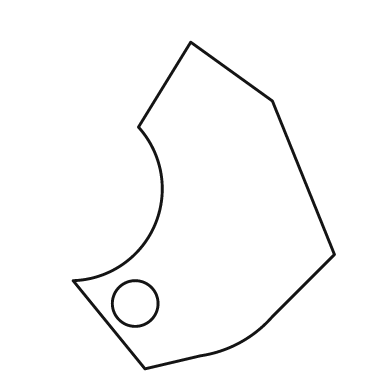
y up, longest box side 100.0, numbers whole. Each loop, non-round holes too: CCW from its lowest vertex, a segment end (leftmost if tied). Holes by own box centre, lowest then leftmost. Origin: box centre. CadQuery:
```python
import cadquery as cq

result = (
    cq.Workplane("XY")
    .moveTo(-18.0, -50.0)
    .lineTo(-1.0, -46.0)
    .threePointArc((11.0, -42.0), (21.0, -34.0))
    .lineTo(40.0, -15.0)
    .lineTo(21.0, 32.0)
    .lineTo(-4.0, 50.0)
    .lineTo(-20.0, 24.0)
    .threePointArc((-15.0, -6.0), (-40.0, -23.0))
    .close()
    .moveTo(-21.0, -30.0)
    .circle(7.0)
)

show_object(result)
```